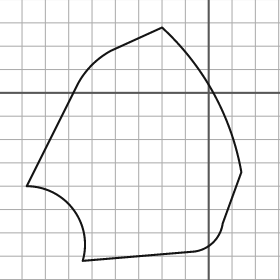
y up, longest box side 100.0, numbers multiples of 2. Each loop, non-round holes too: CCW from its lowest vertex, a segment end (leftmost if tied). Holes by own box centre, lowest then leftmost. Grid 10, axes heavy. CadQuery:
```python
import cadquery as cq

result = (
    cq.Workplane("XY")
    .moveTo(-54.0, -72.0)
    .lineTo(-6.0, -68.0)
    .threePointArc((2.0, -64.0), (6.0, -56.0))
    .lineTo(14.0, -34.0)
    .threePointArc((2.0, 0.0), (-20.0, 28.0))
    .lineTo(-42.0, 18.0)
    .threePointArc((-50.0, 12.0), (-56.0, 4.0))
    .lineTo(-78.0, -40.0)
    .threePointArc((-58.0, -50.0), (-54.0, -72.0))
    .close()
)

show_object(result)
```